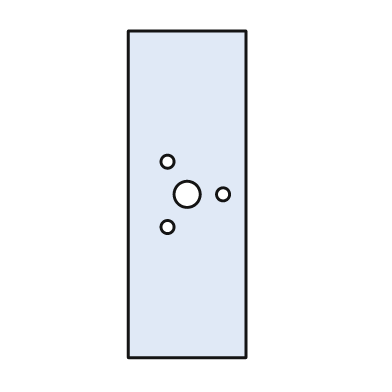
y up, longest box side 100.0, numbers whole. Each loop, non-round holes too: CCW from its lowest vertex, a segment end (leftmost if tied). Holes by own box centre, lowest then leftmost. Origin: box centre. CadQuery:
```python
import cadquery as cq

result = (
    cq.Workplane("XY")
    .moveTo(-18.0, -50.0)
    .lineTo(18.0, -50.0)
    .lineTo(18.0, 50.0)
    .lineTo(-18.0, 50.0)
    .close()
    .moveTo(-6.0, -10.0)
    .circle(2.0)
    .moveTo(0.0, 0.0)
    .circle(4.0)
    .moveTo(11.0, 0.0)
    .circle(2.0)
    .moveTo(-6.0, 10.0)
    .circle(2.0)
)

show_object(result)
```